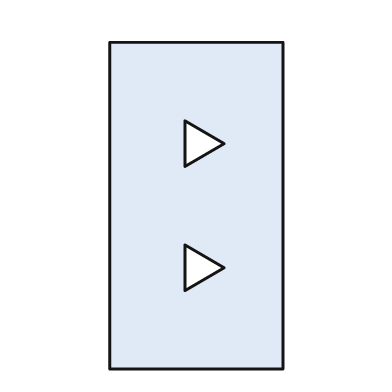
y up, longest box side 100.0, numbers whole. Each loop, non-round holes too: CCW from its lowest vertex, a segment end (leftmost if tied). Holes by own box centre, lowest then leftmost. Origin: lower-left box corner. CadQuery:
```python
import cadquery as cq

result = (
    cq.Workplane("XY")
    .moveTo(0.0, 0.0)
    .lineTo(53.0, 0.0)
    .lineTo(53.0, 100.0)
    .lineTo(0.0, 100.0)
    .close()
    .moveTo(23.0, 24.0)
    .lineTo(35.0, 31.0)
    .lineTo(23.0, 38.0)
    .close()
    .moveTo(23.0, 62.0)
    .lineTo(35.0, 69.0)
    .lineTo(23.0, 76.0)
    .close()
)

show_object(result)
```